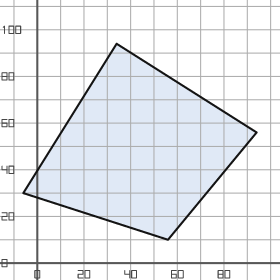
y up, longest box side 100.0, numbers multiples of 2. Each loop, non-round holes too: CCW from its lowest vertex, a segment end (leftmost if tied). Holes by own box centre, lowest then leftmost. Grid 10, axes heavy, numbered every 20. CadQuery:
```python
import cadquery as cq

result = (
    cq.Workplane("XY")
    .moveTo(56.0, 10.0)
    .lineTo(94.0, 56.0)
    .lineTo(34.0, 94.0)
    .lineTo(-6.0, 30.0)
    .close()
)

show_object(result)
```